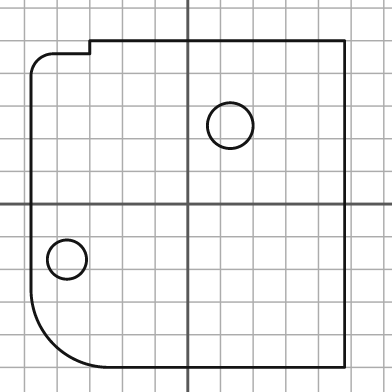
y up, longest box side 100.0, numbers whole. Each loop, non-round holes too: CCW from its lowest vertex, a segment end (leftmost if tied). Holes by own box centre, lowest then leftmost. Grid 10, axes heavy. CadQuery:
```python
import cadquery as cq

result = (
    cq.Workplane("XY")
    .moveTo(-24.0, -50.0)
    .lineTo(48.0, -50.0)
    .lineTo(48.0, 50.0)
    .lineTo(-30.0, 50.0)
    .lineTo(-30.0, 46.0)
    .lineTo(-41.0, 46.0)
    .threePointArc((-46.0, 44.0), (-48.0, 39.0))
    .lineTo(-48.0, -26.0)
    .threePointArc((-41.0, -43.0), (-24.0, -50.0))
    .close()
    .moveTo(-37.0, -17.0)
    .circle(6.0)
    .moveTo(13.0, 24.0)
    .circle(7.0)
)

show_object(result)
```